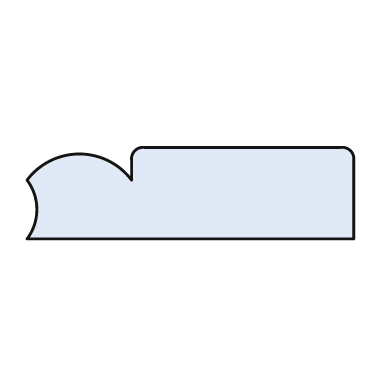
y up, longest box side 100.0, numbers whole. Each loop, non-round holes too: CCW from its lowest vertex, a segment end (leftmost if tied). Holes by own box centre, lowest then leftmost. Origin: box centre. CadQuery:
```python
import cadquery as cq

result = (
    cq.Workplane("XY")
    .moveTo(-50.0, -14.0)
    .lineTo(50.0, -14.0)
    .lineTo(50.0, 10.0)
    .threePointArc((49.0, 13.0), (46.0, 14.0))
    .lineTo(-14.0, 14.0)
    .threePointArc((-17.0, 13.0), (-18.0, 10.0))
    .lineTo(-18.0, 4.0)
    .threePointArc((-34.0, 12.0), (-50.0, 4.0))
    .threePointArc((-47.0, -5.0), (-50.0, -14.0))
    .close()
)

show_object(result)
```